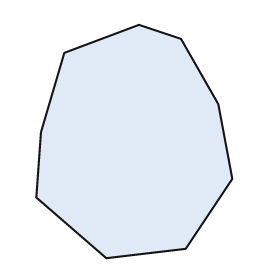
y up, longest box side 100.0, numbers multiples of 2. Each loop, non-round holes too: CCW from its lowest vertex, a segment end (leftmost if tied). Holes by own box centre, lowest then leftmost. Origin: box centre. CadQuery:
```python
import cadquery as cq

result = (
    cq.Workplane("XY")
    .moveTo(-12.0, -50.0)
    .lineTo(22.0, -46.0)
    .lineTo(42.0, -16.0)
    .lineTo(36.0, 16.0)
    .lineTo(20.0, 44.0)
    .lineTo(2.0, 50.0)
    .lineTo(-30.0, 38.0)
    .lineTo(-40.0, 4.0)
    .lineTo(-42.0, -24.0)
    .close()
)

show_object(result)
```